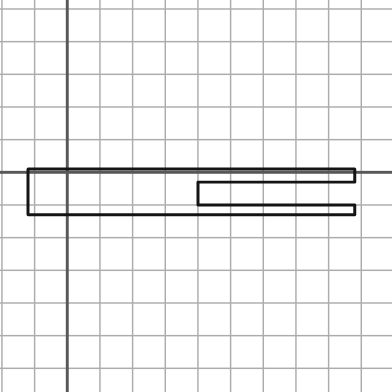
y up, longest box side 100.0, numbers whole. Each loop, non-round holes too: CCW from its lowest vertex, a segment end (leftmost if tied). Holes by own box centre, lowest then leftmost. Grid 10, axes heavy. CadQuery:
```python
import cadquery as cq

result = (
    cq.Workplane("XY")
    .moveTo(-12.0, -13.0)
    .lineTo(88.0, -13.0)
    .lineTo(88.0, -10.0)
    .lineTo(40.0, -10.0)
    .lineTo(40.0, -3.0)
    .lineTo(88.0, -3.0)
    .lineTo(88.0, 1.0)
    .lineTo(-12.0, 1.0)
    .close()
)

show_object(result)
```